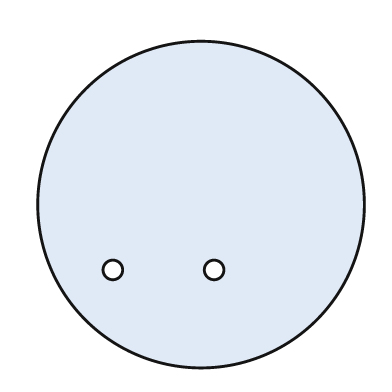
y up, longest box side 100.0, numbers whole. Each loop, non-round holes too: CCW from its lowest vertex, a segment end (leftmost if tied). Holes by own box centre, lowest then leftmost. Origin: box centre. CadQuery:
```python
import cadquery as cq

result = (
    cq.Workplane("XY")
    .moveTo(0.0, 0.0)
    .circle(50.0)
    .moveTo(-27.0, -20.0)
    .circle(3.0)
    .moveTo(4.0, -20.0)
    .circle(3.0)
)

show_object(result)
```